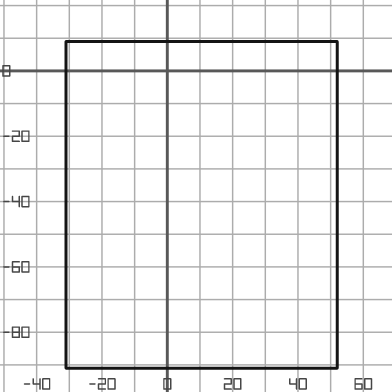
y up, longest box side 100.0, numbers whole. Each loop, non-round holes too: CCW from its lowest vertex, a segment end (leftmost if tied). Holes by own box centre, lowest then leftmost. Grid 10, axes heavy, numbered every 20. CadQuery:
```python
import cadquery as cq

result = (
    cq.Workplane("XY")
    .moveTo(-31.0, -91.0)
    .lineTo(52.0, -91.0)
    .lineTo(52.0, 9.0)
    .lineTo(-31.0, 9.0)
    .close()
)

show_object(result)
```